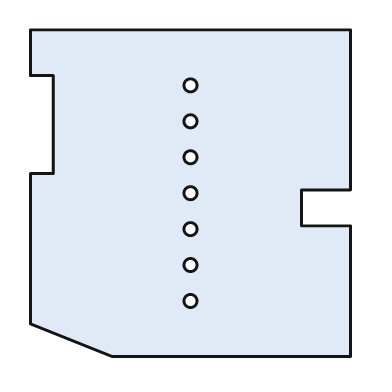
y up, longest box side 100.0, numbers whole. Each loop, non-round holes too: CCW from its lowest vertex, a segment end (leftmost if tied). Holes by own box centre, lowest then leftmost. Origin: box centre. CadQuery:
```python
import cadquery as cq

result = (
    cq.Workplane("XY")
    .moveTo(-24.0, -50.0)
    .lineTo(49.0, -50.0)
    .lineTo(49.0, -10.0)
    .lineTo(34.0, -10.0)
    .lineTo(34.0, 1.0)
    .lineTo(49.0, 1.0)
    .lineTo(49.0, 50.0)
    .lineTo(-49.0, 50.0)
    .lineTo(-49.0, 36.0)
    .lineTo(-42.0, 36.0)
    .lineTo(-42.0, 6.0)
    .lineTo(-49.0, 6.0)
    .lineTo(-49.0, -40.0)
    .close()
    .moveTo(0.0, -33.0)
    .circle(2.0)
    .moveTo(0.0, -22.0)
    .circle(2.0)
    .moveTo(0.0, -11.0)
    .circle(2.0)
    .moveTo(0.0, 0.0)
    .circle(2.0)
    .moveTo(0.0, 11.0)
    .circle(2.0)
    .moveTo(0.0, 22.0)
    .circle(2.0)
    .moveTo(0.0, 33.0)
    .circle(2.0)
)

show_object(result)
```